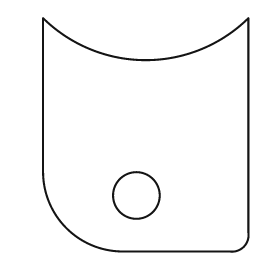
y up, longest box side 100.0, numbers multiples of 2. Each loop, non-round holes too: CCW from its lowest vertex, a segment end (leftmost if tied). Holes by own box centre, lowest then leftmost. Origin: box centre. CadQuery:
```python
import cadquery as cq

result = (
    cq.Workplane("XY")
    .moveTo(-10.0, -50.0)
    .lineTo(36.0, -50.0)
    .threePointArc((42.0, -48.0), (44.0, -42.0))
    .lineTo(44.0, 50.0)
    .threePointArc((0.0, 32.0), (-44.0, 50.0))
    .lineTo(-44.0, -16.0)
    .threePointArc((-34.0, -40.0), (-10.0, -50.0))
    .close()
    .moveTo(-4.0, -26.0)
    .circle(10.0)
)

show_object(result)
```